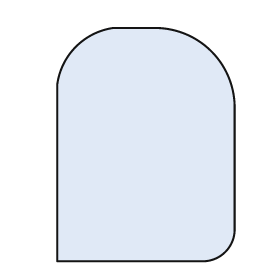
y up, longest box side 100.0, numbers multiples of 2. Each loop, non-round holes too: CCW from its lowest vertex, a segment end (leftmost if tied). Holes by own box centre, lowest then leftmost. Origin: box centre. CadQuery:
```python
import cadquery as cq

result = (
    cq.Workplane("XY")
    .moveTo(-38.0, -50.0)
    .lineTo(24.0, -50.0)
    .threePointArc((34.0, -46.0), (38.0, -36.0))
    .lineTo(38.0, 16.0)
    .threePointArc((28.0, 40.0), (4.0, 50.0))
    .lineTo(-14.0, 50.0)
    .threePointArc((-30.0, 42.0), (-38.0, 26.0))
    .close()
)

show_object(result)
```